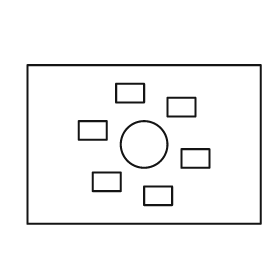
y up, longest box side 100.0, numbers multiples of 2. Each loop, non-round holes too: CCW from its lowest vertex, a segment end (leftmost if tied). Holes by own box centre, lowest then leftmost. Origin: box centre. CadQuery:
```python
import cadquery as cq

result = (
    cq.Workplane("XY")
    .moveTo(-50.0, -34.0)
    .lineTo(50.0, -34.0)
    .lineTo(50.0, 34.0)
    .lineTo(-50.0, 34.0)
    .close()
    .moveTo(0.0, -26.0)
    .lineTo(12.0, -26.0)
    .lineTo(12.0, -18.0)
    .lineTo(0.0, -18.0)
    .close()
    .moveTo(-22.0, -20.0)
    .lineTo(-10.0, -20.0)
    .lineTo(-10.0, -12.0)
    .lineTo(-22.0, -12.0)
    .close()
    .moveTo(16.0, -10.0)
    .lineTo(28.0, -10.0)
    .lineTo(28.0, -2.0)
    .lineTo(16.0, -2.0)
    .close()
    .moveTo(0.0, 0.0)
    .circle(10.0)
    .moveTo(-28.0, 2.0)
    .lineTo(-16.0, 2.0)
    .lineTo(-16.0, 10.0)
    .lineTo(-28.0, 10.0)
    .close()
    .moveTo(10.0, 12.0)
    .lineTo(22.0, 12.0)
    .lineTo(22.0, 20.0)
    .lineTo(10.0, 20.0)
    .close()
    .moveTo(-12.0, 18.0)
    .lineTo(0.0, 18.0)
    .lineTo(0.0, 26.0)
    .lineTo(-12.0, 26.0)
    .close()
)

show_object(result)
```